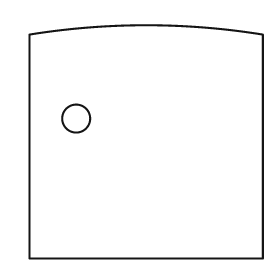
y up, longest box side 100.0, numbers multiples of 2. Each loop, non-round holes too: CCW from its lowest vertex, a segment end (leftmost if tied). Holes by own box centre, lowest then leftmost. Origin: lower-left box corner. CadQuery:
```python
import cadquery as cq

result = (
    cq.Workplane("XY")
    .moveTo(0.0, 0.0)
    .lineTo(100.0, 0.0)
    .lineTo(100.0, 96.0)
    .threePointArc((50.0, 100.0), (0.0, 96.0))
    .close()
    .moveTo(20.0, 60.0)
    .circle(6.0)
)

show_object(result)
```